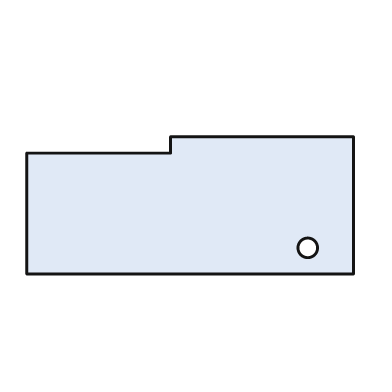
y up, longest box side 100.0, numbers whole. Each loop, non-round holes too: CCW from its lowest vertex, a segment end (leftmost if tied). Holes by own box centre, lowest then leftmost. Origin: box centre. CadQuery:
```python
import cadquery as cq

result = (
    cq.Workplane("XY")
    .moveTo(-50.0, -21.0)
    .lineTo(50.0, -21.0)
    .lineTo(50.0, 21.0)
    .lineTo(-6.0, 21.0)
    .lineTo(-6.0, 16.0)
    .lineTo(-50.0, 16.0)
    .close()
    .moveTo(36.0, -13.0)
    .circle(3.0)
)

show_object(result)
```